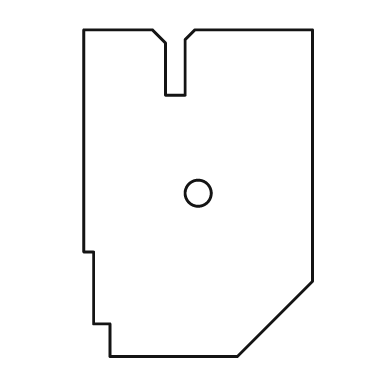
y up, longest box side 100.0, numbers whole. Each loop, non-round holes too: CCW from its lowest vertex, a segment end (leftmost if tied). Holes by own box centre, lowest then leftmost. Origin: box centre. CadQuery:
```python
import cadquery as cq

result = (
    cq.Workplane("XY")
    .moveTo(-27.0, -50.0)
    .lineTo(12.0, -50.0)
    .lineTo(35.0, -27.0)
    .lineTo(35.0, 50.0)
    .lineTo(-1.0, 50.0)
    .lineTo(-4.0, 47.0)
    .lineTo(-4.0, 30.0)
    .lineTo(-10.0, 30.0)
    .lineTo(-10.0, 46.0)
    .lineTo(-14.0, 50.0)
    .lineTo(-35.0, 50.0)
    .lineTo(-35.0, -18.0)
    .lineTo(-32.0, -18.0)
    .lineTo(-32.0, -40.0)
    .lineTo(-27.0, -40.0)
    .close()
    .moveTo(0.0, 0.0)
    .circle(4.0)
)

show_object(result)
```